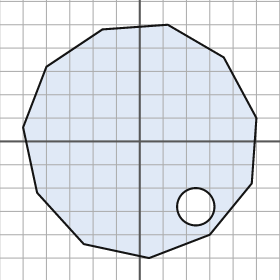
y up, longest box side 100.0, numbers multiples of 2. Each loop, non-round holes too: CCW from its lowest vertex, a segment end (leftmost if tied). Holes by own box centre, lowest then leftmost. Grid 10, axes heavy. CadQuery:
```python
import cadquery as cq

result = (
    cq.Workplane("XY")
    .moveTo(4.0, -50.0)
    .lineTo(30.0, -40.0)
    .lineTo(48.0, -18.0)
    .lineTo(50.0, 10.0)
    .lineTo(36.0, 36.0)
    .lineTo(12.0, 50.0)
    .lineTo(-16.0, 48.0)
    .lineTo(-40.0, 32.0)
    .lineTo(-50.0, 6.0)
    .lineTo(-44.0, -22.0)
    .lineTo(-24.0, -44.0)
    .close()
    .moveTo(24.0, -28.0)
    .circle(8.0)
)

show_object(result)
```